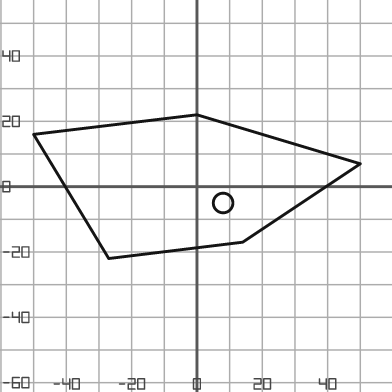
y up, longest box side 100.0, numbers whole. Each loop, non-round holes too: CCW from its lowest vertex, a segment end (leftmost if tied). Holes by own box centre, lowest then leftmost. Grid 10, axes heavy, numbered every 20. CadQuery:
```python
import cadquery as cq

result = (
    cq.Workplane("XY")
    .moveTo(-27.0, -22.0)
    .lineTo(14.0, -17.0)
    .lineTo(50.0, 7.0)
    .lineTo(0.0, 22.0)
    .lineTo(-50.0, 16.0)
    .close()
    .moveTo(8.0, -5.0)
    .circle(3.0)
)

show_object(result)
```